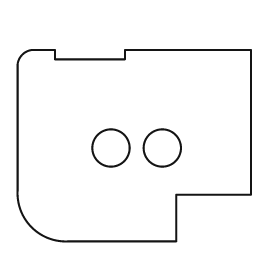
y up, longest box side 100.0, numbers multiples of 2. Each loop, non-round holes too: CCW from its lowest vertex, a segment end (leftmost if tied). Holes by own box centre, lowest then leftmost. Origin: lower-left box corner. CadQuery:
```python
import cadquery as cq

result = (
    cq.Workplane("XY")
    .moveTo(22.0, 0.0)
    .lineTo(68.0, 0.0)
    .lineTo(68.0, 20.0)
    .lineTo(100.0, 20.0)
    .lineTo(100.0, 82.0)
    .lineTo(46.0, 82.0)
    .lineTo(46.0, 78.0)
    .lineTo(16.0, 78.0)
    .lineTo(16.0, 82.0)
    .lineTo(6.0, 82.0)
    .threePointArc((2.0, 80.0), (0.0, 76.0))
    .lineTo(0.0, 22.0)
    .threePointArc((6.0, 6.0), (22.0, 0.0))
    .close()
    .moveTo(40.0, 40.0)
    .circle(8.0)
    .moveTo(62.0, 40.0)
    .circle(8.0)
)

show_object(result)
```